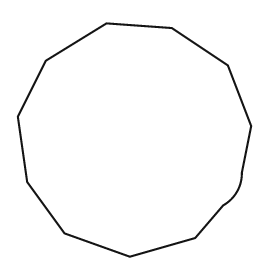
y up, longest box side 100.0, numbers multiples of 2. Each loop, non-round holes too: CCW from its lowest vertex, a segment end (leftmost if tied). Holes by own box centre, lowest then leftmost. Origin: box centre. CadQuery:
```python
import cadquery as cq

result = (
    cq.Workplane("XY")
    .moveTo(-2.0, -50.0)
    .lineTo(26.0, -42.0)
    .lineTo(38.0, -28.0)
    .threePointArc((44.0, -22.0), (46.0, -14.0))
    .lineTo(50.0, 6.0)
    .lineTo(40.0, 32.0)
    .lineTo(16.0, 48.0)
    .lineTo(-12.0, 50.0)
    .lineTo(-38.0, 34.0)
    .lineTo(-50.0, 10.0)
    .lineTo(-46.0, -18.0)
    .lineTo(-30.0, -40.0)
    .close()
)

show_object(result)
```